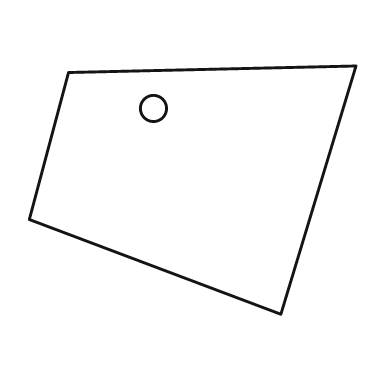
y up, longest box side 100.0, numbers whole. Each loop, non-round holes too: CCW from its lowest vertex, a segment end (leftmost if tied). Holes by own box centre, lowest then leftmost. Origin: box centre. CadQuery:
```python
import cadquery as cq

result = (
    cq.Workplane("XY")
    .moveTo(27.0, -38.0)
    .lineTo(50.0, 38.0)
    .lineTo(-38.0, 36.0)
    .lineTo(-50.0, -9.0)
    .close()
    .moveTo(-12.0, 25.0)
    .circle(4.0)
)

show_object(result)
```